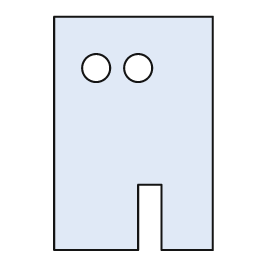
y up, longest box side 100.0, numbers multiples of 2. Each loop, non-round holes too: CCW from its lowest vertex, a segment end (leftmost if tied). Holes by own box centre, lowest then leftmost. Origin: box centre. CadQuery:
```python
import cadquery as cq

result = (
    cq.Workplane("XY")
    .moveTo(-34.0, -50.0)
    .lineTo(2.0, -50.0)
    .lineTo(2.0, -22.0)
    .lineTo(12.0, -22.0)
    .lineTo(12.0, -50.0)
    .lineTo(34.0, -50.0)
    .lineTo(34.0, 50.0)
    .lineTo(-34.0, 50.0)
    .close()
    .moveTo(-16.0, 28.0)
    .circle(6.0)
    .moveTo(2.0, 28.0)
    .circle(6.0)
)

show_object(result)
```